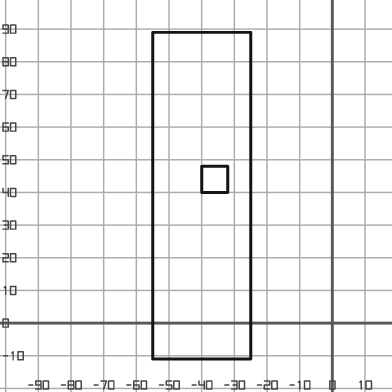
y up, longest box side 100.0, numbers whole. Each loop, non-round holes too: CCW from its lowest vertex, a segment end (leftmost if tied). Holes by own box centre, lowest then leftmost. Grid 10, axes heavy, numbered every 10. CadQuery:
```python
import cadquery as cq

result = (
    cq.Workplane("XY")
    .moveTo(-55.0, -11.0)
    .lineTo(-25.0, -11.0)
    .lineTo(-25.0, 89.0)
    .lineTo(-55.0, 89.0)
    .close()
    .moveTo(-40.0, 40.0)
    .lineTo(-32.0, 40.0)
    .lineTo(-32.0, 48.0)
    .lineTo(-40.0, 48.0)
    .close()
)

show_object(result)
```